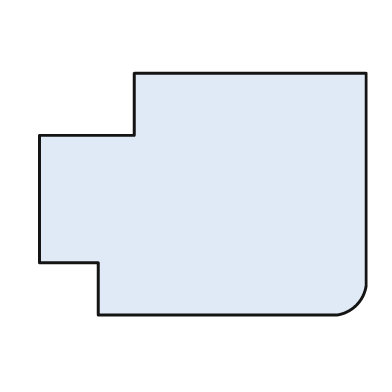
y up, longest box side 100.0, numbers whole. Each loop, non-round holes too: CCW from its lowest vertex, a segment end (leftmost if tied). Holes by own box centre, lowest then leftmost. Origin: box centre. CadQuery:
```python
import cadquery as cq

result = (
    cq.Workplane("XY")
    .moveTo(-32.0, -37.0)
    .lineTo(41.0, -37.0)
    .threePointArc((47.0, -34.0), (50.0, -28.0))
    .lineTo(50.0, 37.0)
    .lineTo(-21.0, 37.0)
    .lineTo(-21.0, 18.0)
    .lineTo(-50.0, 18.0)
    .lineTo(-50.0, -21.0)
    .lineTo(-32.0, -21.0)
    .close()
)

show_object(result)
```